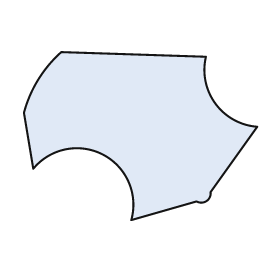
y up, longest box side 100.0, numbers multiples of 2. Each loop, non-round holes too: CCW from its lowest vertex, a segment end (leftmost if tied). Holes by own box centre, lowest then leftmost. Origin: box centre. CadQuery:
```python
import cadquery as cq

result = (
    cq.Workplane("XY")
    .moveTo(-4.0, -36.0)
    .lineTo(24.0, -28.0)
    .threePointArc((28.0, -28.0), (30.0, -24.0))
    .lineTo(50.0, 4.0)
    .threePointArc((32.0, 14.0), (28.0, 34.0))
    .lineTo(-34.0, 36.0)
    .threePointArc((-44.0, 24.0), (-50.0, 10.0))
    .lineTo(-46.0, -14.0)
    .threePointArc((-16.0, -8.0), (-4.0, -36.0))
    .close()
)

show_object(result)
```